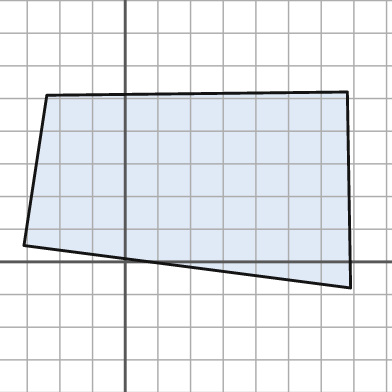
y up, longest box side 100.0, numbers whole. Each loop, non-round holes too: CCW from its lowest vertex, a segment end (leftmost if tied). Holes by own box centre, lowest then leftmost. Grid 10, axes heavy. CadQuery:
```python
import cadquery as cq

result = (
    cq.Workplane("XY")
    .moveTo(69.0, -8.0)
    .lineTo(68.0, 52.0)
    .lineTo(-24.0, 51.0)
    .lineTo(-31.0, 5.0)
    .close()
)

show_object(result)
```